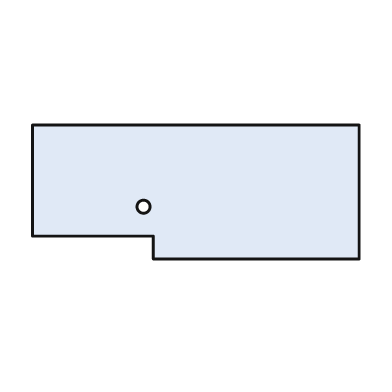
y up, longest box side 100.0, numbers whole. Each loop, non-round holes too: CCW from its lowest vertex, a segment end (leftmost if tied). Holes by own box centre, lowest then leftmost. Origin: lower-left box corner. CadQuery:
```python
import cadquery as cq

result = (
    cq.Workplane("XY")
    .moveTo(37.0, 0.0)
    .lineTo(100.0, 0.0)
    .lineTo(100.0, 41.0)
    .lineTo(0.0, 41.0)
    .lineTo(0.0, 7.0)
    .lineTo(37.0, 7.0)
    .close()
    .moveTo(34.0, 16.0)
    .circle(2.0)
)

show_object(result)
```